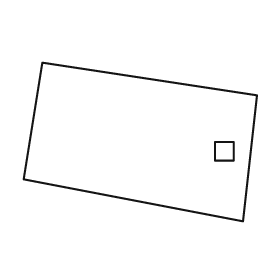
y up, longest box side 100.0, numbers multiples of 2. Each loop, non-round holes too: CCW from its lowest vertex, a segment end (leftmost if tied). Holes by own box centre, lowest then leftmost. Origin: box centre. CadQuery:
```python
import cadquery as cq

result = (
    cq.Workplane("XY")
    .moveTo(44.0, -34.0)
    .lineTo(50.0, 20.0)
    .lineTo(-42.0, 34.0)
    .lineTo(-50.0, -16.0)
    .close()
    .moveTo(32.0, -8.0)
    .lineTo(40.0, -8.0)
    .lineTo(40.0, 0.0)
    .lineTo(32.0, 0.0)
    .close()
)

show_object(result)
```